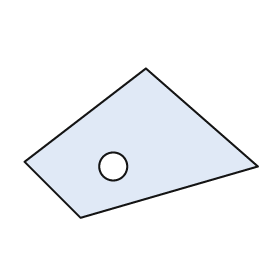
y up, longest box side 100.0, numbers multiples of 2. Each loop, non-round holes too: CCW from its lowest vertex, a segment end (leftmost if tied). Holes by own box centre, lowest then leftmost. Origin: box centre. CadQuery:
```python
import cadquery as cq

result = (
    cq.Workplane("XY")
    .moveTo(-26.0, -32.0)
    .lineTo(50.0, -10.0)
    .lineTo(2.0, 32.0)
    .lineTo(-50.0, -8.0)
    .close()
    .moveTo(-12.0, -10.0)
    .circle(6.0)
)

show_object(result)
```